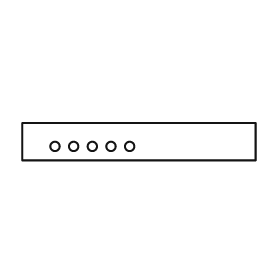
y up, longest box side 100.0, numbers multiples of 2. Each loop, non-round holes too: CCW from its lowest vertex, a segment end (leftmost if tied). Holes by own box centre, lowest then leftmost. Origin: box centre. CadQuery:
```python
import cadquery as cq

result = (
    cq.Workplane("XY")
    .moveTo(-50.0, -8.0)
    .lineTo(50.0, -8.0)
    .lineTo(50.0, 8.0)
    .lineTo(-50.0, 8.0)
    .close()
    .moveTo(-36.0, -2.0)
    .circle(2.0)
    .moveTo(-28.0, -2.0)
    .circle(2.0)
    .moveTo(-20.0, -2.0)
    .circle(2.0)
    .moveTo(-12.0, -2.0)
    .circle(2.0)
    .moveTo(-4.0, -2.0)
    .circle(2.0)
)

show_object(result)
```